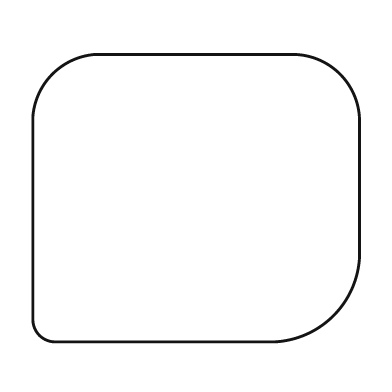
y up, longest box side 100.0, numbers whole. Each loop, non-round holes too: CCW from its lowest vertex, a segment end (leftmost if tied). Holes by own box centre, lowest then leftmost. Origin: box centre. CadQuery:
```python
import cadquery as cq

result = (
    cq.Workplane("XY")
    .moveTo(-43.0, -44.0)
    .lineTo(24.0, -44.0)
    .threePointArc((42.0, -36.0), (50.0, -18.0))
    .lineTo(50.0, 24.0)
    .threePointArc((44.0, 38.0), (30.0, 44.0))
    .lineTo(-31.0, 44.0)
    .threePointArc((-44.0, 38.0), (-50.0, 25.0))
    .lineTo(-50.0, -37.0)
    .threePointArc((-48.0, -42.0), (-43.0, -44.0))
    .close()
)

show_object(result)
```